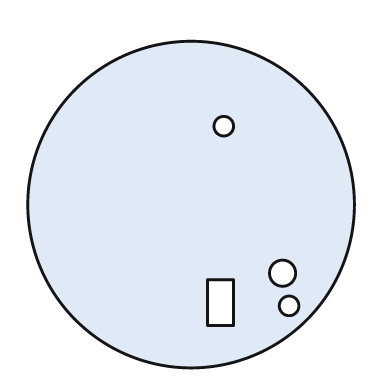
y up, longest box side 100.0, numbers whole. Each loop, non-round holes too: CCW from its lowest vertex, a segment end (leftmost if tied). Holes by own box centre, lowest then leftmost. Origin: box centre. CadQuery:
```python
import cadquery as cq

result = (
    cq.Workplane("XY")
    .moveTo(0.0, 0.0)
    .circle(50.0)
    .moveTo(30.0, -31.0)
    .circle(3.0)
    .moveTo(5.0, -37.0)
    .lineTo(13.0, -37.0)
    .lineTo(13.0, -23.0)
    .lineTo(5.0, -23.0)
    .close()
    .moveTo(28.0, -21.0)
    .circle(4.0)
    .moveTo(10.0, 24.0)
    .circle(3.0)
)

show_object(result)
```